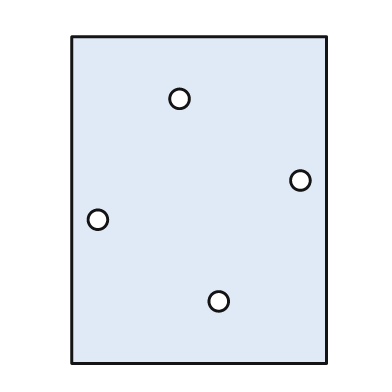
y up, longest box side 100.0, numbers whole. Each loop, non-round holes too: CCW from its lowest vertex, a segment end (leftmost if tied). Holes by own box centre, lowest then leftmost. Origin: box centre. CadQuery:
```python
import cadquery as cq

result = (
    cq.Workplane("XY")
    .moveTo(-39.0, -50.0)
    .lineTo(39.0, -50.0)
    .lineTo(39.0, 50.0)
    .lineTo(-39.0, 50.0)
    .close()
    .moveTo(6.0, -31.0)
    .circle(3.0)
    .moveTo(-31.0, -6.0)
    .circle(3.0)
    .moveTo(31.0, 6.0)
    .circle(3.0)
    .moveTo(-6.0, 31.0)
    .circle(3.0)
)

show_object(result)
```